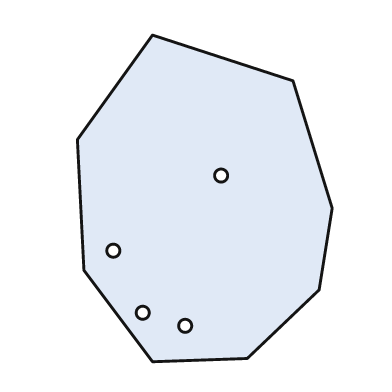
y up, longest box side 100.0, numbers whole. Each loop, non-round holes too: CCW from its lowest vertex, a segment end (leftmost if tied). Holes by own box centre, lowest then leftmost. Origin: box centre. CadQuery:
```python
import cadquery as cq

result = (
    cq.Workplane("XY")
    .moveTo(-16.0, -50.0)
    .lineTo(13.0, -49.0)
    .lineTo(35.0, -28.0)
    .lineTo(39.0, -3.0)
    .lineTo(27.0, 36.0)
    .lineTo(-16.0, 50.0)
    .lineTo(-39.0, 18.0)
    .lineTo(-37.0, -22.0)
    .close()
    .moveTo(-6.0, -39.0)
    .circle(2.0)
    .moveTo(-19.0, -35.0)
    .circle(2.0)
    .moveTo(-28.0, -16.0)
    .circle(2.0)
    .moveTo(5.0, 7.0)
    .circle(2.0)
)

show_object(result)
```